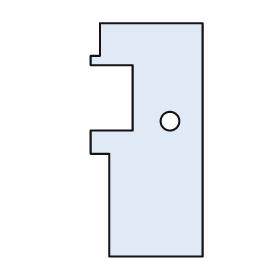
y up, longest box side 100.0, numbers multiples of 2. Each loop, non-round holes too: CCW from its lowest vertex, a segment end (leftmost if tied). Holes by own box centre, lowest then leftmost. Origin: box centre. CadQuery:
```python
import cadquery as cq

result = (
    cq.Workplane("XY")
    .moveTo(-16.0, -50.0)
    .lineTo(24.0, -50.0)
    .lineTo(24.0, 50.0)
    .lineTo(-20.0, 50.0)
    .lineTo(-20.0, 36.0)
    .lineTo(-24.0, 36.0)
    .lineTo(-24.0, 32.0)
    .lineTo(-6.0, 32.0)
    .lineTo(-6.0, 4.0)
    .lineTo(-24.0, 4.0)
    .lineTo(-24.0, -6.0)
    .lineTo(-16.0, -6.0)
    .close()
    .moveTo(10.0, 8.0)
    .circle(4.0)
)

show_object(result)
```